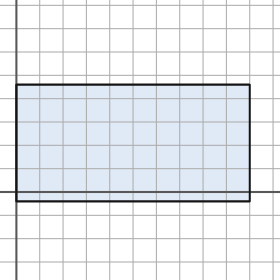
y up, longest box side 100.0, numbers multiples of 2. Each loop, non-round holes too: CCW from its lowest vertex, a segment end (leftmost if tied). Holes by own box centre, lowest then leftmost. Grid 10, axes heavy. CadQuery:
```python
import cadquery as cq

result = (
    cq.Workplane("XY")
    .moveTo(0.0, -4.0)
    .lineTo(100.0, -4.0)
    .lineTo(100.0, 46.0)
    .lineTo(0.0, 46.0)
    .close()
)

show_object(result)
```